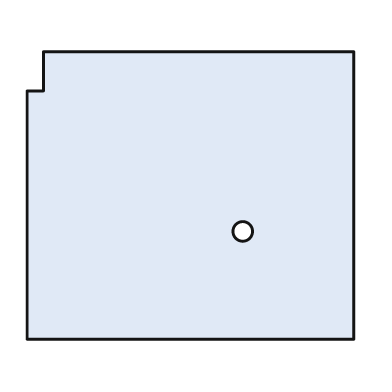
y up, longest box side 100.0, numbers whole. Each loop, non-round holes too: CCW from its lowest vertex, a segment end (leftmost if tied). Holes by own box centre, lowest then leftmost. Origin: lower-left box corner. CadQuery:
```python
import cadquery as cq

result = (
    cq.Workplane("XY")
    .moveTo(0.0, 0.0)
    .lineTo(100.0, 0.0)
    .lineTo(100.0, 88.0)
    .lineTo(5.0, 88.0)
    .lineTo(5.0, 76.0)
    .lineTo(0.0, 76.0)
    .close()
    .moveTo(66.0, 33.0)
    .circle(3.0)
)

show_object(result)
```